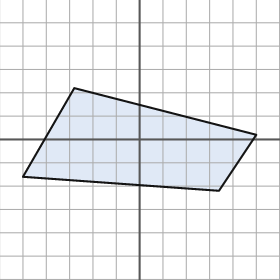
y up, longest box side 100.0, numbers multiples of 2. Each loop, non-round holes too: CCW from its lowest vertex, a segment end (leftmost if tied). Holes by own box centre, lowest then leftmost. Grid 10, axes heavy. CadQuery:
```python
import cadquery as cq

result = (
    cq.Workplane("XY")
    .moveTo(34.0, -22.0)
    .lineTo(50.0, 2.0)
    .lineTo(-28.0, 22.0)
    .lineTo(-50.0, -16.0)
    .close()
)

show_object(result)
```